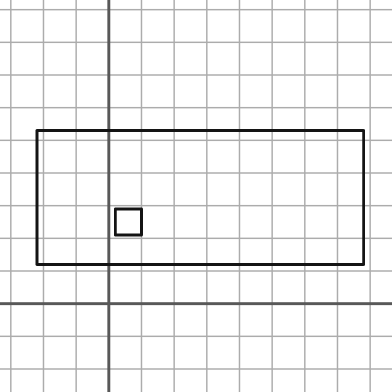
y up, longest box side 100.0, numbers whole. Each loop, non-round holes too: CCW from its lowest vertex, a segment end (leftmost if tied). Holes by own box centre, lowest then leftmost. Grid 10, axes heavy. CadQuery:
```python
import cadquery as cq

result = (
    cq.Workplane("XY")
    .moveTo(-22.0, 12.0)
    .lineTo(78.0, 12.0)
    .lineTo(78.0, 53.0)
    .lineTo(-22.0, 53.0)
    .close()
    .moveTo(2.0, 21.0)
    .lineTo(10.0, 21.0)
    .lineTo(10.0, 29.0)
    .lineTo(2.0, 29.0)
    .close()
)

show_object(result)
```